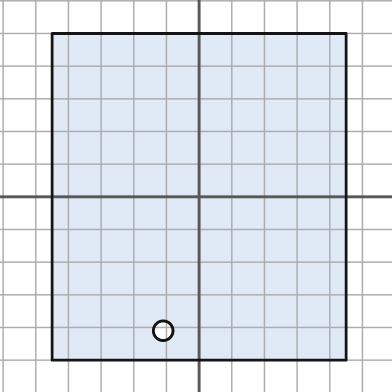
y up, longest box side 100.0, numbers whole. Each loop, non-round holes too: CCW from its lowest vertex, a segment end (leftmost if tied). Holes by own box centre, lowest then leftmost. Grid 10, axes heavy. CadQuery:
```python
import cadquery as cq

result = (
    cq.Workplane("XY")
    .moveTo(-45.0, -50.0)
    .lineTo(45.0, -50.0)
    .lineTo(45.0, 50.0)
    .lineTo(-45.0, 50.0)
    .close()
    .moveTo(-11.0, -41.0)
    .circle(3.0)
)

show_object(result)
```